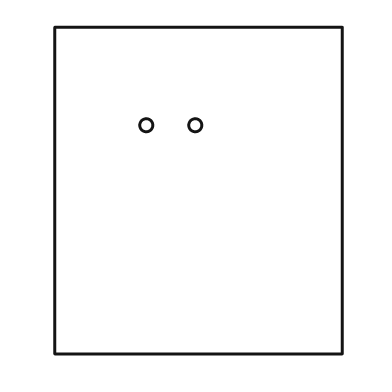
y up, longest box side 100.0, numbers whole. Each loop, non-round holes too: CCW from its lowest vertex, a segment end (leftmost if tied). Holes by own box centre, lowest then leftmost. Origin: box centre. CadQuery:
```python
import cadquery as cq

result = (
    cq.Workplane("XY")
    .moveTo(-44.0, -50.0)
    .lineTo(44.0, -50.0)
    .lineTo(44.0, 50.0)
    .lineTo(-44.0, 50.0)
    .close()
    .moveTo(-16.0, 20.0)
    .circle(2.0)
    .moveTo(-1.0, 20.0)
    .circle(2.0)
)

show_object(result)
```